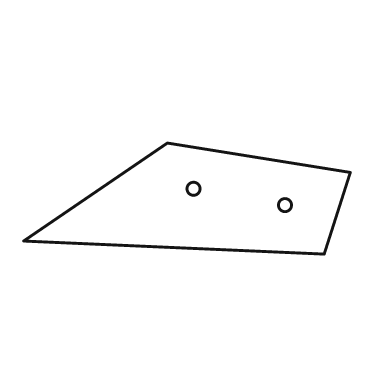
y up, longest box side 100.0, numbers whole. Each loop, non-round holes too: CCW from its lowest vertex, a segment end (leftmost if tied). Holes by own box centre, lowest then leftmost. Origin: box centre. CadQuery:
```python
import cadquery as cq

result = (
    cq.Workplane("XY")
    .moveTo(42.0, -17.0)
    .lineTo(50.0, 8.0)
    .lineTo(-6.0, 17.0)
    .lineTo(-50.0, -13.0)
    .close()
    .moveTo(30.0, -2.0)
    .circle(2.0)
    .moveTo(2.0, 3.0)
    .circle(2.0)
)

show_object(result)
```